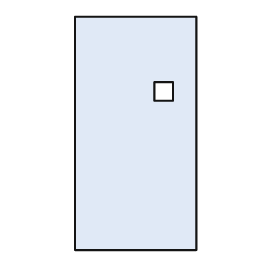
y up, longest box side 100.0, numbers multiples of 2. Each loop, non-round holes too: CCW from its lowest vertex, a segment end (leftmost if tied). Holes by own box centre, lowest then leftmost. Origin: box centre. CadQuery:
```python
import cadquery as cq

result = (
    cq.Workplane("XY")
    .moveTo(-26.0, -50.0)
    .lineTo(26.0, -50.0)
    .lineTo(26.0, 50.0)
    .lineTo(-26.0, 50.0)
    .close()
    .moveTo(8.0, 14.0)
    .lineTo(16.0, 14.0)
    .lineTo(16.0, 22.0)
    .lineTo(8.0, 22.0)
    .close()
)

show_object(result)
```